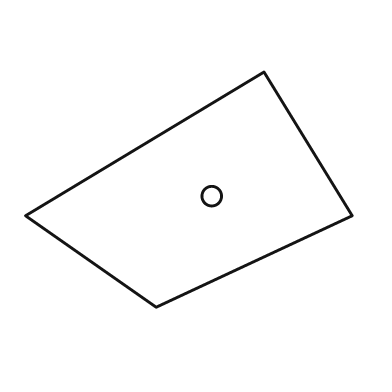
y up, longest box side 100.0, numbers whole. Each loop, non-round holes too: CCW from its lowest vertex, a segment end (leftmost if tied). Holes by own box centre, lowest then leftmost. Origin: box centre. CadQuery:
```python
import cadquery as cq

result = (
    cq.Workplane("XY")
    .moveTo(-10.0, -36.0)
    .lineTo(50.0, -8.0)
    .lineTo(23.0, 36.0)
    .lineTo(-50.0, -8.0)
    .close()
    .moveTo(7.0, -2.0)
    .circle(3.0)
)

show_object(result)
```